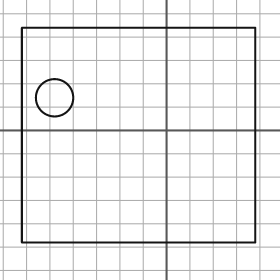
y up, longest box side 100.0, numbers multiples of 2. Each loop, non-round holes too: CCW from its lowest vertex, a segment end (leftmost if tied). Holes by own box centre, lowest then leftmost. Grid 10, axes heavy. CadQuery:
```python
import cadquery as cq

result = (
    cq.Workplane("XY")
    .moveTo(-62.0, -48.0)
    .lineTo(38.0, -48.0)
    .lineTo(38.0, 44.0)
    .lineTo(-62.0, 44.0)
    .close()
    .moveTo(-48.0, 14.0)
    .circle(8.0)
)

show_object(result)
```